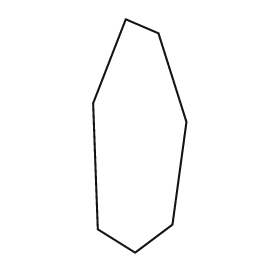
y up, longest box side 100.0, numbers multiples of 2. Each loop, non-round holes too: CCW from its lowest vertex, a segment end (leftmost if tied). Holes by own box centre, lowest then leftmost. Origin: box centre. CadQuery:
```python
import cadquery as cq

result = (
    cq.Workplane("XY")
    .moveTo(-2.0, -50.0)
    .lineTo(14.0, -38.0)
    .lineTo(20.0, 6.0)
    .lineTo(8.0, 44.0)
    .lineTo(-6.0, 50.0)
    .lineTo(-20.0, 14.0)
    .lineTo(-18.0, -40.0)
    .close()
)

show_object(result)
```